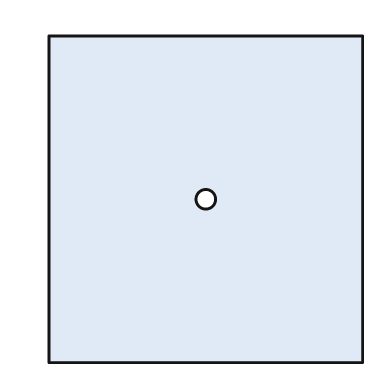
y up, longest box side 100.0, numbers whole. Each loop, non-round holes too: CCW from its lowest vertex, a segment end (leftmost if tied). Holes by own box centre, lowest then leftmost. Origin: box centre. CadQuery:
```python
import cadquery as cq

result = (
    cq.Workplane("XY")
    .moveTo(-48.0, -50.0)
    .lineTo(48.0, -50.0)
    .lineTo(48.0, 50.0)
    .lineTo(-48.0, 50.0)
    .close()
    .moveTo(0.0, 0.0)
    .circle(3.0)
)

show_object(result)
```